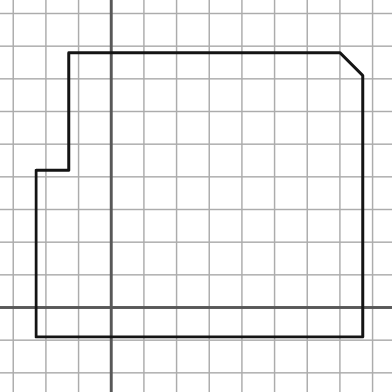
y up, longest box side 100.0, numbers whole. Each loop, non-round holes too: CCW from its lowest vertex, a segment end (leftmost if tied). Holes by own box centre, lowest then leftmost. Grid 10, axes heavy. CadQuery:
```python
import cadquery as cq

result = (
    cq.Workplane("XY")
    .moveTo(-23.0, -9.0)
    .lineTo(77.0, -9.0)
    .lineTo(77.0, 71.0)
    .lineTo(70.0, 78.0)
    .lineTo(-13.0, 78.0)
    .lineTo(-13.0, 42.0)
    .lineTo(-23.0, 42.0)
    .close()
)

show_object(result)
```